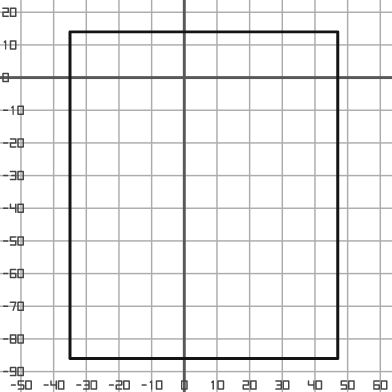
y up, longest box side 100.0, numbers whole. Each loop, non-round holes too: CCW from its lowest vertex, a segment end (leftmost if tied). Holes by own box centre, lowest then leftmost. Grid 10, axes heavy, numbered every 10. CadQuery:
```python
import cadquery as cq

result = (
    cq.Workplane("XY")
    .moveTo(-35.0, -86.0)
    .lineTo(47.0, -86.0)
    .lineTo(47.0, 14.0)
    .lineTo(-35.0, 14.0)
    .close()
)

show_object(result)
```